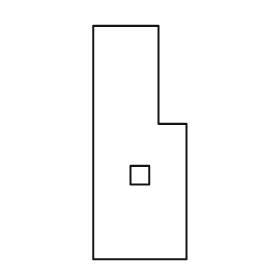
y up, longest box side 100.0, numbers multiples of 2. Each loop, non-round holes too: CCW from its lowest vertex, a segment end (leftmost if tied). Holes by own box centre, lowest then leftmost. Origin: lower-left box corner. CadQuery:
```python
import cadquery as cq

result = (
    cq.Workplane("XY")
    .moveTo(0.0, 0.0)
    .lineTo(40.0, 0.0)
    .lineTo(40.0, 58.0)
    .lineTo(28.0, 58.0)
    .lineTo(28.0, 100.0)
    .lineTo(0.0, 100.0)
    .close()
    .moveTo(16.0, 32.0)
    .lineTo(24.0, 32.0)
    .lineTo(24.0, 40.0)
    .lineTo(16.0, 40.0)
    .close()
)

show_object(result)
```